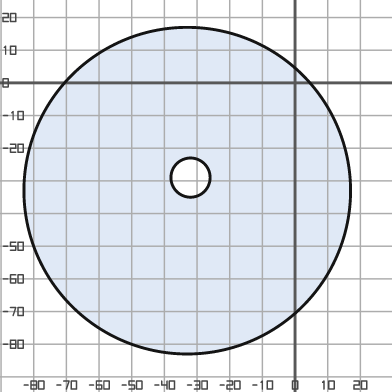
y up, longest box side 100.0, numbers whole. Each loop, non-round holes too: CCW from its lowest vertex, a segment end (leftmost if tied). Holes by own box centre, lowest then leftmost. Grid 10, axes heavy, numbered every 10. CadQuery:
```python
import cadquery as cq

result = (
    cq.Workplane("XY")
    .moveTo(-33.0, -33.0)
    .circle(50.0)
    .moveTo(-32.0, -29.0)
    .circle(6.0)
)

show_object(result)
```